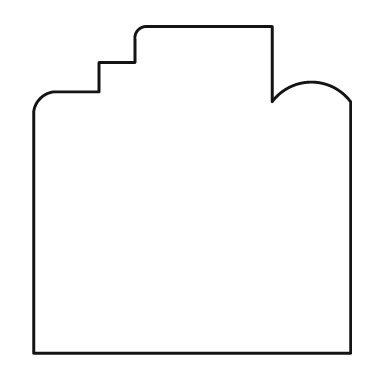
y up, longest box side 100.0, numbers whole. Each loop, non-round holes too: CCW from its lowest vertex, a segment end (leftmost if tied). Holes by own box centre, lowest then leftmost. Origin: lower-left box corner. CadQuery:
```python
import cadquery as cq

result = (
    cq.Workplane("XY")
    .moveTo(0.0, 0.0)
    .lineTo(97.0, 0.0)
    .lineTo(97.0, 77.0)
    .threePointArc((85.0, 83.0), (73.0, 77.0))
    .lineTo(73.0, 100.0)
    .lineTo(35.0, 100.0)
    .threePointArc((32.0, 99.0), (31.0, 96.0))
    .lineTo(31.0, 89.0)
    .lineTo(20.0, 89.0)
    .lineTo(20.0, 80.0)
    .lineTo(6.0, 80.0)
    .threePointArc((2.0, 78.0), (0.0, 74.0))
    .close()
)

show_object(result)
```